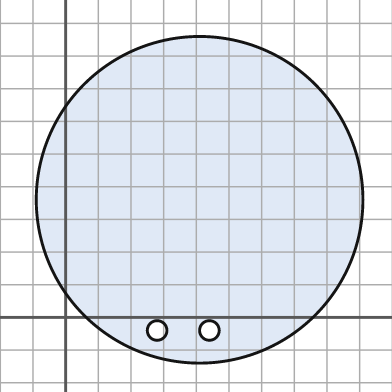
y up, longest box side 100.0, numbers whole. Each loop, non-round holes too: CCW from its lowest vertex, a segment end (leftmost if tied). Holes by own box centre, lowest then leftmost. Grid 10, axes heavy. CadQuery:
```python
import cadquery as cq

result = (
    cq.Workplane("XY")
    .moveTo(41.0, 36.0)
    .circle(50.0)
    .moveTo(28.0, -4.0)
    .circle(3.0)
    .moveTo(44.0, -4.0)
    .circle(3.0)
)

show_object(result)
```